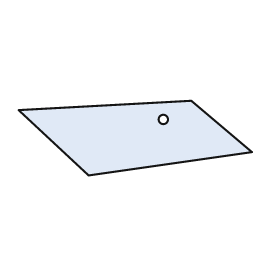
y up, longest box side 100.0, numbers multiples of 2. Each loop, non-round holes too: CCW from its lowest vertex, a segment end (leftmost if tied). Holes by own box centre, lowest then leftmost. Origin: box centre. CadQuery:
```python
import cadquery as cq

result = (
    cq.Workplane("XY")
    .moveTo(-20.0, -16.0)
    .lineTo(50.0, -6.0)
    .lineTo(24.0, 16.0)
    .lineTo(-50.0, 12.0)
    .close()
    .moveTo(12.0, 8.0)
    .circle(2.0)
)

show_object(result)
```